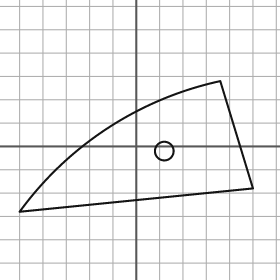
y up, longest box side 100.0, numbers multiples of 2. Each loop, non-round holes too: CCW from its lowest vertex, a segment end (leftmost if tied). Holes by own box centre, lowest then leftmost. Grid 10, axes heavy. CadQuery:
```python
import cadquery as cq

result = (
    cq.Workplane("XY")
    .moveTo(-50.0, -28.0)
    .lineTo(50.0, -18.0)
    .lineTo(36.0, 28.0)
    .threePointArc((-12.0, 8.0), (-50.0, -28.0))
    .close()
    .moveTo(12.0, -2.0)
    .circle(4.0)
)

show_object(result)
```